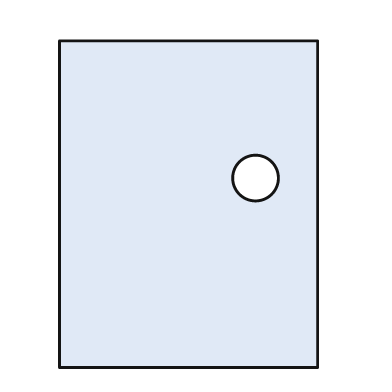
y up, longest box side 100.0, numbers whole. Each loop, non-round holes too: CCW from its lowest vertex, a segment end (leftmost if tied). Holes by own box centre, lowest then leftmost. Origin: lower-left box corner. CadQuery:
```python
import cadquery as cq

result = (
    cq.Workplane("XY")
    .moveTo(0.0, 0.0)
    .lineTo(79.0, 0.0)
    .lineTo(79.0, 100.0)
    .lineTo(0.0, 100.0)
    .close()
    .moveTo(60.0, 58.0)
    .circle(7.0)
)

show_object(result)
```